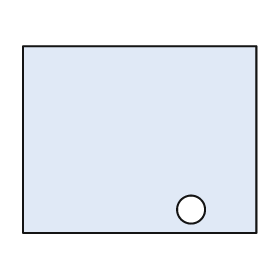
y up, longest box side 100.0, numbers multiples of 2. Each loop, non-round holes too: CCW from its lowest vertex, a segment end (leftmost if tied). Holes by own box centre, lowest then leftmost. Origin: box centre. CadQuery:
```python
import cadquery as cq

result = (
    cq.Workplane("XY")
    .moveTo(-50.0, -40.0)
    .lineTo(50.0, -40.0)
    .lineTo(50.0, 40.0)
    .lineTo(-50.0, 40.0)
    .close()
    .moveTo(22.0, -30.0)
    .circle(6.0)
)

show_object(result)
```